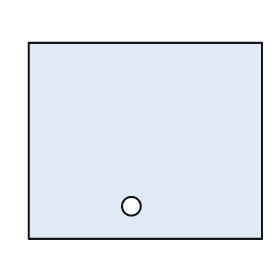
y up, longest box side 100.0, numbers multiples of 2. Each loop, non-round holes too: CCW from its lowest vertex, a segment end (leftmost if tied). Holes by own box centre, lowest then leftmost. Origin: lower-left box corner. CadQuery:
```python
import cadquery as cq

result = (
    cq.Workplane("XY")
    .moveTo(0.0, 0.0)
    .lineTo(100.0, 0.0)
    .lineTo(100.0, 84.0)
    .lineTo(0.0, 84.0)
    .close()
    .moveTo(44.0, 14.0)
    .circle(4.0)
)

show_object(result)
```